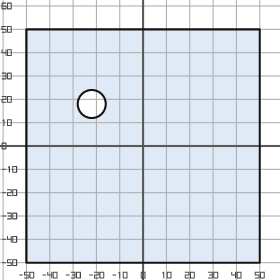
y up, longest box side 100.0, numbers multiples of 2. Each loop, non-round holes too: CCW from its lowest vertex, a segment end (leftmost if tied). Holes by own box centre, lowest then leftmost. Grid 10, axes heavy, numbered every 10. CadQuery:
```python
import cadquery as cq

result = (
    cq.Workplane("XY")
    .moveTo(-50.0, -50.0)
    .lineTo(50.0, -50.0)
    .lineTo(50.0, 50.0)
    .lineTo(-50.0, 50.0)
    .close()
    .moveTo(-22.0, 18.0)
    .circle(6.0)
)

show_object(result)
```